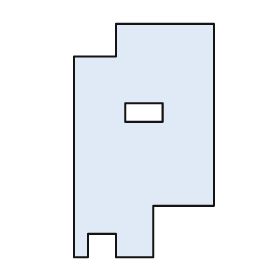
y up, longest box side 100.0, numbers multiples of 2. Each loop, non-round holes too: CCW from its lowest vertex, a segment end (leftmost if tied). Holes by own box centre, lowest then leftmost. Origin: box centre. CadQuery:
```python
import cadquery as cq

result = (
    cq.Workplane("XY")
    .moveTo(-30.0, -50.0)
    .lineTo(-24.0, -50.0)
    .lineTo(-24.0, -40.0)
    .lineTo(-12.0, -40.0)
    .lineTo(-12.0, -50.0)
    .lineTo(4.0, -50.0)
    .lineTo(4.0, -28.0)
    .lineTo(30.0, -28.0)
    .lineTo(30.0, 50.0)
    .lineTo(-12.0, 50.0)
    .lineTo(-12.0, 36.0)
    .lineTo(-30.0, 36.0)
    .close()
    .moveTo(-8.0, 8.0)
    .lineTo(8.0, 8.0)
    .lineTo(8.0, 16.0)
    .lineTo(-8.0, 16.0)
    .close()
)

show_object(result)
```